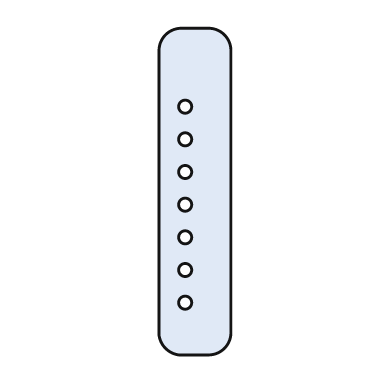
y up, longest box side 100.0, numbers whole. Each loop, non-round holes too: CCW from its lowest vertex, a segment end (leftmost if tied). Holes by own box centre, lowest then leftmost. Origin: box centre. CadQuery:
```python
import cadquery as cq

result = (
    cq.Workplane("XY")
    .moveTo(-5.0, -50.0)
    .lineTo(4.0, -50.0)
    .threePointArc((9.0, -48.0), (11.0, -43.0))
    .lineTo(11.0, 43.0)
    .threePointArc((9.0, 48.0), (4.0, 50.0))
    .lineTo(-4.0, 50.0)
    .threePointArc((-9.0, 48.0), (-11.0, 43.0))
    .lineTo(-11.0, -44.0)
    .threePointArc((-9.0, -48.0), (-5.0, -50.0))
    .close()
    .moveTo(-3.0, -34.0)
    .circle(2.0)
    .moveTo(-3.0, -24.0)
    .circle(2.0)
    .moveTo(-3.0, -14.0)
    .circle(2.0)
    .moveTo(-3.0, -4.0)
    .circle(2.0)
    .moveTo(-3.0, 6.0)
    .circle(2.0)
    .moveTo(-3.0, 16.0)
    .circle(2.0)
    .moveTo(-3.0, 26.0)
    .circle(2.0)
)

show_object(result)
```